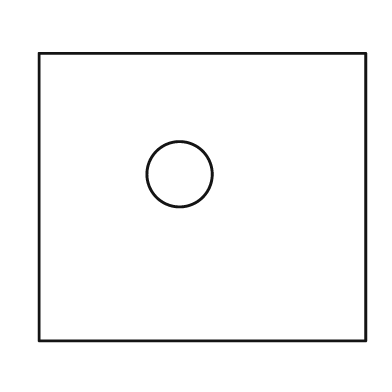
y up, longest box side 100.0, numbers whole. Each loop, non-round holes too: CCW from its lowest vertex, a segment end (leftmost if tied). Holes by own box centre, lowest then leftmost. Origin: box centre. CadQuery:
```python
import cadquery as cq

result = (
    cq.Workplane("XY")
    .moveTo(-50.0, -44.0)
    .lineTo(50.0, -44.0)
    .lineTo(50.0, 44.0)
    .lineTo(-50.0, 44.0)
    .close()
    .moveTo(-7.0, 7.0)
    .circle(10.0)
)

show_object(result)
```